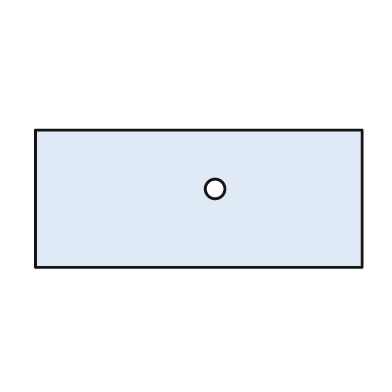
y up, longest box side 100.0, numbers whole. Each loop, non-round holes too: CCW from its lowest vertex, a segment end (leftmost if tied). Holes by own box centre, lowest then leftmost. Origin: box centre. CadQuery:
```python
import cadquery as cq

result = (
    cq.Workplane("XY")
    .moveTo(-50.0, -21.0)
    .lineTo(50.0, -21.0)
    .lineTo(50.0, 21.0)
    .lineTo(-50.0, 21.0)
    .close()
    .moveTo(5.0, 3.0)
    .circle(3.0)
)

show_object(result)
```